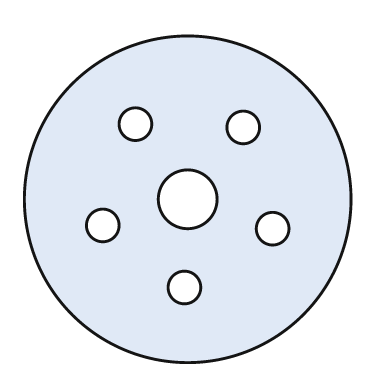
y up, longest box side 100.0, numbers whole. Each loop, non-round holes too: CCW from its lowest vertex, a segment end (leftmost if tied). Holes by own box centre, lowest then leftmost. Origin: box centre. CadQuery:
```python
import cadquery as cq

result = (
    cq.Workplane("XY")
    .moveTo(0.0, 0.0)
    .circle(50.0)
    .moveTo(-1.0, -27.0)
    .circle(5.0)
    .moveTo(26.0, -9.0)
    .circle(5.0)
    .moveTo(-26.0, -8.0)
    .circle(5.0)
    .moveTo(0.0, 0.0)
    .circle(9.0)
    .moveTo(17.0, 22.0)
    .circle(5.0)
    .moveTo(-16.0, 23.0)
    .circle(5.0)
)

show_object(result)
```